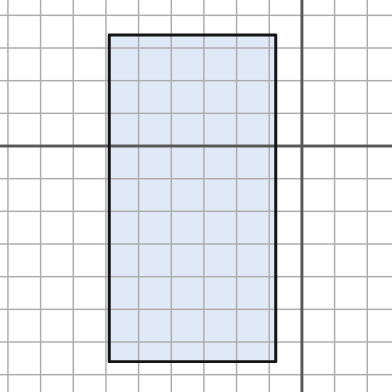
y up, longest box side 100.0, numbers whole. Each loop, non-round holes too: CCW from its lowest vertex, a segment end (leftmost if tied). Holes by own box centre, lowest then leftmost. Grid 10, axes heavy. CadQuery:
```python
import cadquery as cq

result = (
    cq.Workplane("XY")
    .moveTo(-59.0, -66.0)
    .lineTo(-8.0, -66.0)
    .lineTo(-8.0, 34.0)
    .lineTo(-59.0, 34.0)
    .close()
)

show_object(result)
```